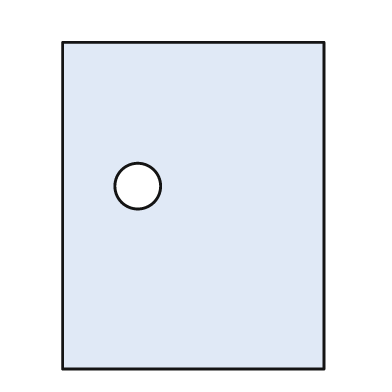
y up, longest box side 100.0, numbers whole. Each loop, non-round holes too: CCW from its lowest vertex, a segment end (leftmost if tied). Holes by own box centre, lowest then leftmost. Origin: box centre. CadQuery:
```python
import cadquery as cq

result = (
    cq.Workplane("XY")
    .moveTo(-40.0, -50.0)
    .lineTo(40.0, -50.0)
    .lineTo(40.0, 50.0)
    .lineTo(-40.0, 50.0)
    .close()
    .moveTo(-17.0, 6.0)
    .circle(7.0)
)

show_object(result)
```